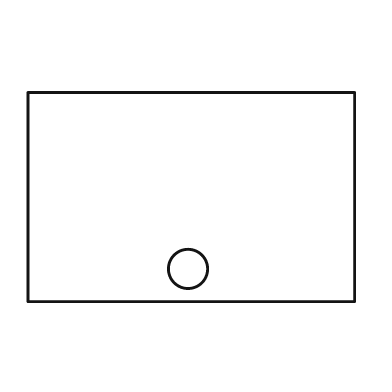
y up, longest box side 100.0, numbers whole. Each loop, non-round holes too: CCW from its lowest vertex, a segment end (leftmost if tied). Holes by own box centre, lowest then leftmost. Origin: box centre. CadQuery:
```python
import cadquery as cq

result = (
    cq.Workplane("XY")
    .moveTo(-50.0, -32.0)
    .lineTo(50.0, -32.0)
    .lineTo(50.0, 32.0)
    .lineTo(-50.0, 32.0)
    .close()
    .moveTo(-1.0, -22.0)
    .circle(6.0)
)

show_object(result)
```